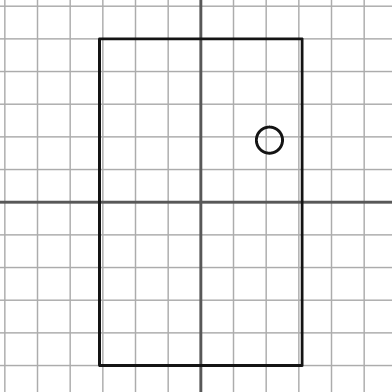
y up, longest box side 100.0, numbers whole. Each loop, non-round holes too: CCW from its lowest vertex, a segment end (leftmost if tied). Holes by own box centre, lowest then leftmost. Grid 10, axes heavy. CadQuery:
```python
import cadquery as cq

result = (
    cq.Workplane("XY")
    .moveTo(-31.0, -50.0)
    .lineTo(31.0, -50.0)
    .lineTo(31.0, 50.0)
    .lineTo(-31.0, 50.0)
    .close()
    .moveTo(21.0, 19.0)
    .circle(4.0)
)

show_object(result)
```